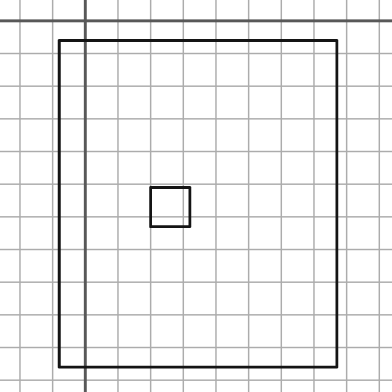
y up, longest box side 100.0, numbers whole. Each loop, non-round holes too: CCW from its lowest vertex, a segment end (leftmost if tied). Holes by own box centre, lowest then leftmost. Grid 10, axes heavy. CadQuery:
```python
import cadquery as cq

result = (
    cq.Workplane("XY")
    .moveTo(-8.0, -106.0)
    .lineTo(77.0, -106.0)
    .lineTo(77.0, -6.0)
    .lineTo(-8.0, -6.0)
    .close()
    .moveTo(20.0, -63.0)
    .lineTo(32.0, -63.0)
    .lineTo(32.0, -51.0)
    .lineTo(20.0, -51.0)
    .close()
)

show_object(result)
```